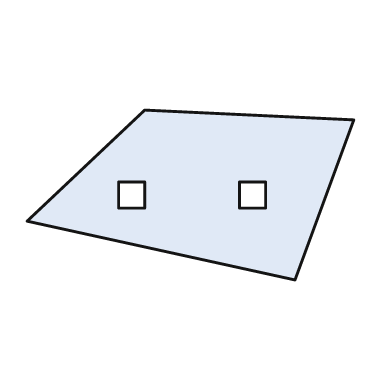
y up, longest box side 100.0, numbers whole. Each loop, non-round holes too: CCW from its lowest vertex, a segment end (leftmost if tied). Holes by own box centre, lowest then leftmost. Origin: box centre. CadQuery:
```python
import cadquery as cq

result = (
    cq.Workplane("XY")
    .moveTo(32.0, -26.0)
    .lineTo(50.0, 23.0)
    .lineTo(-14.0, 26.0)
    .lineTo(-50.0, -8.0)
    .close()
    .moveTo(-22.0, -4.0)
    .lineTo(-14.0, -4.0)
    .lineTo(-14.0, 4.0)
    .lineTo(-22.0, 4.0)
    .close()
    .moveTo(15.0, -4.0)
    .lineTo(23.0, -4.0)
    .lineTo(23.0, 4.0)
    .lineTo(15.0, 4.0)
    .close()
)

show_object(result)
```